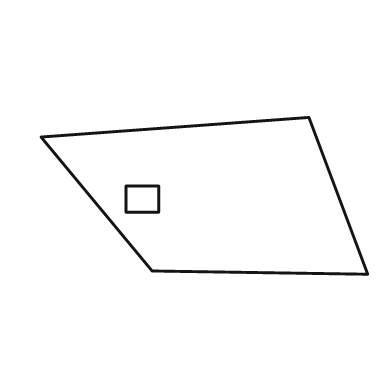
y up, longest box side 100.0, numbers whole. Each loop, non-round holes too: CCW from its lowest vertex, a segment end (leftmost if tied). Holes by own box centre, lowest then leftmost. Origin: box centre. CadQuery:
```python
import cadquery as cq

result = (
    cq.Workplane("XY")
    .moveTo(50.0, -24.0)
    .lineTo(32.0, 24.0)
    .lineTo(-50.0, 18.0)
    .lineTo(-16.0, -23.0)
    .close()
    .moveTo(-24.0, -5.0)
    .lineTo(-14.0, -5.0)
    .lineTo(-14.0, 3.0)
    .lineTo(-24.0, 3.0)
    .close()
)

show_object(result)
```